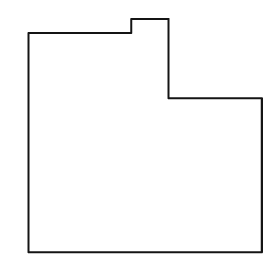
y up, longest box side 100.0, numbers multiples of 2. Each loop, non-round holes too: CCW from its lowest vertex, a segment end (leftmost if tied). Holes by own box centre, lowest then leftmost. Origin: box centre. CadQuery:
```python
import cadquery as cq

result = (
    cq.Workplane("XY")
    .moveTo(-50.0, -50.0)
    .lineTo(50.0, -50.0)
    .lineTo(50.0, 16.0)
    .lineTo(10.0, 16.0)
    .lineTo(10.0, 50.0)
    .lineTo(-6.0, 50.0)
    .lineTo(-6.0, 44.0)
    .lineTo(-50.0, 44.0)
    .close()
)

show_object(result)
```